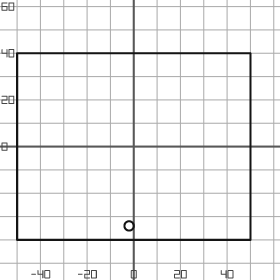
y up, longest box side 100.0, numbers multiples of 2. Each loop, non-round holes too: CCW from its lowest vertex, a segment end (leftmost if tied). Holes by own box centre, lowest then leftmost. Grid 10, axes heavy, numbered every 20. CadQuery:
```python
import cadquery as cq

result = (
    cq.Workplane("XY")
    .moveTo(-50.0, -40.0)
    .lineTo(50.0, -40.0)
    .lineTo(50.0, 40.0)
    .lineTo(-50.0, 40.0)
    .close()
    .moveTo(-2.0, -34.0)
    .circle(2.0)
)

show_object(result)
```